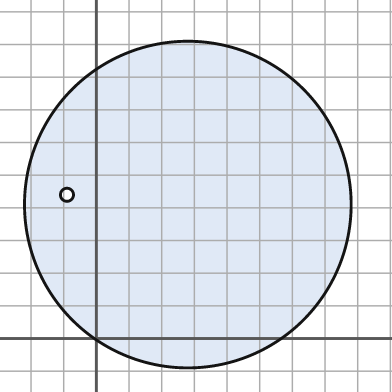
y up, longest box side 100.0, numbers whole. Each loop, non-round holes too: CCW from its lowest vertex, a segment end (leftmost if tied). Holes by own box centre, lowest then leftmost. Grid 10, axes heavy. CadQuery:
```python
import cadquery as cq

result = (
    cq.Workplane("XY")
    .moveTo(28.0, 41.0)
    .circle(50.0)
    .moveTo(-9.0, 44.0)
    .circle(2.0)
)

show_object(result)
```